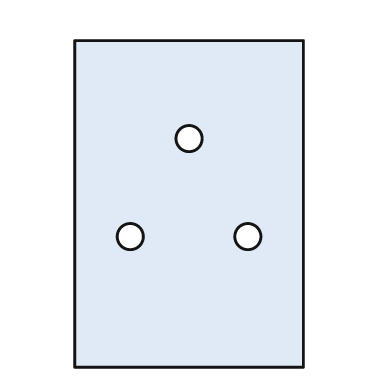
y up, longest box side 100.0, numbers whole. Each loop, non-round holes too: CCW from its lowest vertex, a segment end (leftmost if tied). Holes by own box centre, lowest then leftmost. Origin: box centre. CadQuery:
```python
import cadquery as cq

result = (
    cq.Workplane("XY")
    .moveTo(-35.0, -50.0)
    .lineTo(35.0, -50.0)
    .lineTo(35.0, 50.0)
    .lineTo(-35.0, 50.0)
    .close()
    .moveTo(-18.0, -10.0)
    .circle(4.0)
    .moveTo(18.0, -10.0)
    .circle(4.0)
    .moveTo(0.0, 20.0)
    .circle(4.0)
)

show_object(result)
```